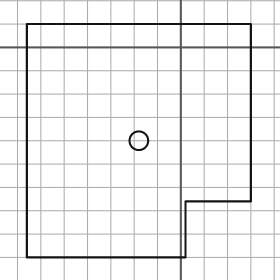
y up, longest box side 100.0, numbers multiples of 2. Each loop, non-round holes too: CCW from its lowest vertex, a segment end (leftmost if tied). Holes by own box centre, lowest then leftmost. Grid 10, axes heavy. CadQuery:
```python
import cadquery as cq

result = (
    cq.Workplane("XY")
    .moveTo(-66.0, -90.0)
    .lineTo(2.0, -90.0)
    .lineTo(2.0, -66.0)
    .lineTo(30.0, -66.0)
    .lineTo(30.0, 10.0)
    .lineTo(-66.0, 10.0)
    .close()
    .moveTo(-18.0, -40.0)
    .circle(4.0)
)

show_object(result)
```